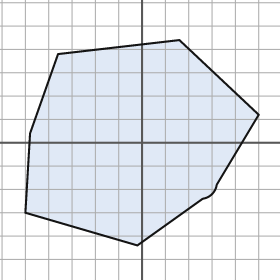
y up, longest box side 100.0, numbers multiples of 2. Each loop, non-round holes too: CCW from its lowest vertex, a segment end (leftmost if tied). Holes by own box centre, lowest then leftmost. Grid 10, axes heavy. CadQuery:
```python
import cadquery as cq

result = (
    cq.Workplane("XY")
    .moveTo(-2.0, -44.0)
    .lineTo(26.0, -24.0)
    .threePointArc((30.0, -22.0), (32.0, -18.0))
    .lineTo(50.0, 12.0)
    .lineTo(16.0, 44.0)
    .lineTo(-36.0, 38.0)
    .lineTo(-48.0, 4.0)
    .lineTo(-50.0, -30.0)
    .close()
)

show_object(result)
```